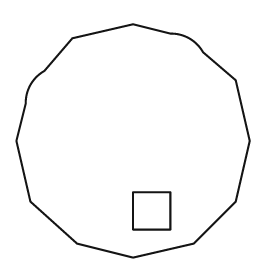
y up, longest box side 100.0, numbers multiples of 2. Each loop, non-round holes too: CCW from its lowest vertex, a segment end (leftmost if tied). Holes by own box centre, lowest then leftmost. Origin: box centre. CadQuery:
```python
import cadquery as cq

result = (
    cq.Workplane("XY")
    .moveTo(0.0, -50.0)
    .lineTo(26.0, -44.0)
    .lineTo(44.0, -26.0)
    .lineTo(50.0, 0.0)
    .lineTo(44.0, 26.0)
    .lineTo(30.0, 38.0)
    .threePointArc((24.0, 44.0), (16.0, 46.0))
    .lineTo(0.0, 50.0)
    .lineTo(-26.0, 44.0)
    .lineTo(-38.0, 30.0)
    .threePointArc((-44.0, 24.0), (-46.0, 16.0))
    .lineTo(-50.0, 0.0)
    .lineTo(-44.0, -26.0)
    .lineTo(-24.0, -44.0)
    .close()
    .moveTo(0.0, -38.0)
    .lineTo(16.0, -38.0)
    .lineTo(16.0, -22.0)
    .lineTo(0.0, -22.0)
    .close()
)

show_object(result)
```